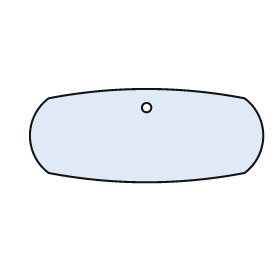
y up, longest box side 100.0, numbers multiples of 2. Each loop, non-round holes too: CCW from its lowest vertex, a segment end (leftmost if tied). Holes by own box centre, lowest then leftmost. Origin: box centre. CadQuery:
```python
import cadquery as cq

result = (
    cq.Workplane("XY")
    .moveTo(-42.0, -16.0)
    .threePointArc((0.0, -20.0), (42.0, -16.0))
    .threePointArc((50.0, 0.0), (42.0, 16.0))
    .threePointArc((0.0, 20.0), (-42.0, 16.0))
    .threePointArc((-50.0, 0.0), (-42.0, -16.0))
    .close()
    .moveTo(0.0, 12.0)
    .circle(2.0)
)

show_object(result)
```